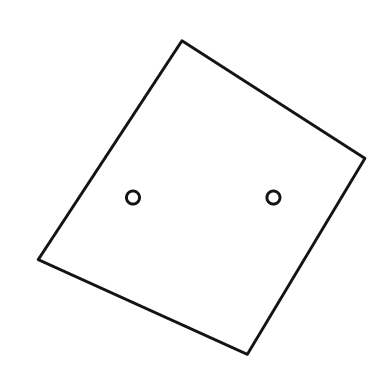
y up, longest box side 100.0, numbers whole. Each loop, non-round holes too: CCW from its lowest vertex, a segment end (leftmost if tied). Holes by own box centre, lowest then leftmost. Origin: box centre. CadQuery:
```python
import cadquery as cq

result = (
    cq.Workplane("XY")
    .moveTo(14.0, -48.0)
    .lineTo(50.0, 12.0)
    .lineTo(-6.0, 48.0)
    .lineTo(-50.0, -19.0)
    .close()
    .moveTo(-21.0, 0.0)
    .circle(2.0)
    .moveTo(22.0, 0.0)
    .circle(2.0)
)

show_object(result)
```